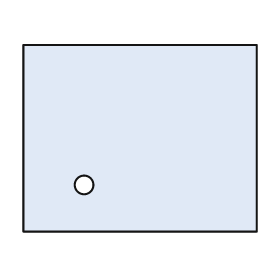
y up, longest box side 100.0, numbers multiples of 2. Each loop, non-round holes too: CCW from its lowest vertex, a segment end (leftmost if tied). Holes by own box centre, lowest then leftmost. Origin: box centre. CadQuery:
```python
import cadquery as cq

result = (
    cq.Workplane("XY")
    .moveTo(-50.0, -40.0)
    .lineTo(50.0, -40.0)
    .lineTo(50.0, 40.0)
    .lineTo(-50.0, 40.0)
    .close()
    .moveTo(-24.0, -20.0)
    .circle(4.0)
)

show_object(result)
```